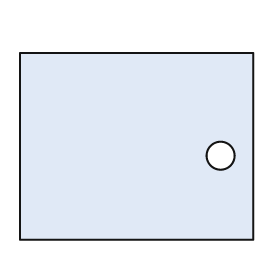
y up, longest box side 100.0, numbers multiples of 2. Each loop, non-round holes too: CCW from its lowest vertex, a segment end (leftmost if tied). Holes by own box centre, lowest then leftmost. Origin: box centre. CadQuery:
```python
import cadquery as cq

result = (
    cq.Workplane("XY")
    .moveTo(-50.0, -40.0)
    .lineTo(50.0, -40.0)
    .lineTo(50.0, 40.0)
    .lineTo(-50.0, 40.0)
    .close()
    .moveTo(36.0, -4.0)
    .circle(6.0)
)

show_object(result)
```